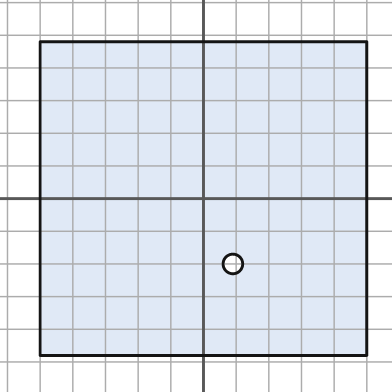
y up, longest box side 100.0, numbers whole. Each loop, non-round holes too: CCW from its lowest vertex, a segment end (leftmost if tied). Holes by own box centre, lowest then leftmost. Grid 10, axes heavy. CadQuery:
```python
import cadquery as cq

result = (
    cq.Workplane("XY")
    .moveTo(-50.0, -48.0)
    .lineTo(50.0, -48.0)
    .lineTo(50.0, 48.0)
    .lineTo(-50.0, 48.0)
    .close()
    .moveTo(9.0, -20.0)
    .circle(3.0)
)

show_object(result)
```